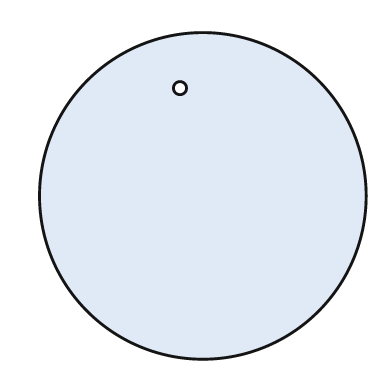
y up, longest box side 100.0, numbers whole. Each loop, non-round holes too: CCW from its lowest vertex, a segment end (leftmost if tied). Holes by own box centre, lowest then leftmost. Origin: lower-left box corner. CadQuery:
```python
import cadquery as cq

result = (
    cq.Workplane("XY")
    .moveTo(50.0, 50.0)
    .circle(50.0)
    .moveTo(43.0, 83.0)
    .circle(2.0)
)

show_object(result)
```